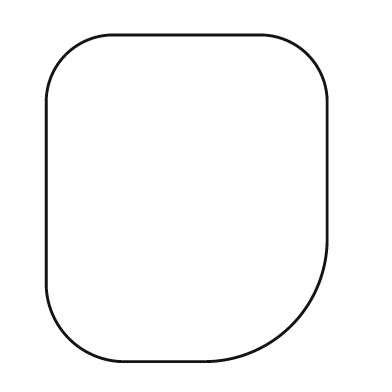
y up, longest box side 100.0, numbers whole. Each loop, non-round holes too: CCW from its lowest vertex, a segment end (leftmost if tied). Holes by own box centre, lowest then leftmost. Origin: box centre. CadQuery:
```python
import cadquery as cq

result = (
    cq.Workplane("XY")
    .moveTo(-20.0, -50.0)
    .lineTo(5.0, -50.0)
    .threePointArc((32.0, -39.0), (43.0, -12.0))
    .lineTo(43.0, 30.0)
    .threePointArc((37.0, 44.0), (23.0, 50.0))
    .lineTo(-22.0, 50.0)
    .threePointArc((-37.0, 44.0), (-43.0, 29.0))
    .lineTo(-43.0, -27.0)
    .threePointArc((-36.0, -43.0), (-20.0, -50.0))
    .close()
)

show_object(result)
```